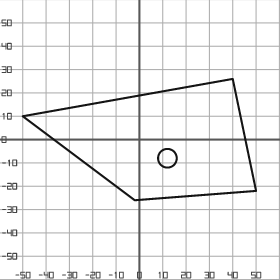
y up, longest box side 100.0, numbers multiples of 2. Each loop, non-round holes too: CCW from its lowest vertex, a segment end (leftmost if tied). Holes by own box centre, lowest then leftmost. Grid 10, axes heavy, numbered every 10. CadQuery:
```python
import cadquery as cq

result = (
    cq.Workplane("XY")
    .moveTo(-2.0, -26.0)
    .lineTo(50.0, -22.0)
    .lineTo(40.0, 26.0)
    .lineTo(-50.0, 10.0)
    .close()
    .moveTo(12.0, -8.0)
    .circle(4.0)
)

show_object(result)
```